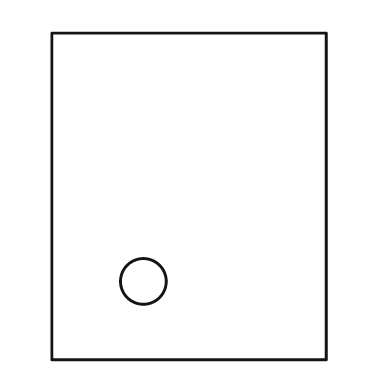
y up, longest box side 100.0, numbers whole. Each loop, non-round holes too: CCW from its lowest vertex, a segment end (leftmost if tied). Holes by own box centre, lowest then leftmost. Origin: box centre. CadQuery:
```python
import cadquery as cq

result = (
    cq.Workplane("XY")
    .moveTo(-42.0, -50.0)
    .lineTo(42.0, -50.0)
    .lineTo(42.0, 50.0)
    .lineTo(-42.0, 50.0)
    .close()
    .moveTo(-14.0, -26.0)
    .circle(7.0)
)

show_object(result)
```